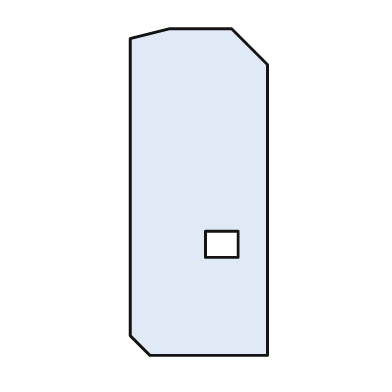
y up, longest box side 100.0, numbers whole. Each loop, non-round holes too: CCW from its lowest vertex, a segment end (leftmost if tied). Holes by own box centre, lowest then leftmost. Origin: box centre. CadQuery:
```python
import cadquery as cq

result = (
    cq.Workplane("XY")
    .moveTo(-15.0, -50.0)
    .lineTo(21.0, -50.0)
    .lineTo(21.0, 39.0)
    .lineTo(10.0, 50.0)
    .lineTo(-9.0, 50.0)
    .lineTo(-21.0, 47.0)
    .lineTo(-21.0, -44.0)
    .close()
    .moveTo(2.0, -20.0)
    .lineTo(12.0, -20.0)
    .lineTo(12.0, -12.0)
    .lineTo(2.0, -12.0)
    .close()
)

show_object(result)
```